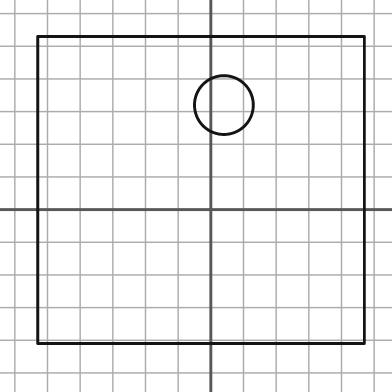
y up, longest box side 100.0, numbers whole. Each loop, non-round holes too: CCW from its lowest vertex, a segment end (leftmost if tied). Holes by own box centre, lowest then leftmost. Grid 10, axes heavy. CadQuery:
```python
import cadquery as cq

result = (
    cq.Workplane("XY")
    .moveTo(-53.0, -41.0)
    .lineTo(47.0, -41.0)
    .lineTo(47.0, 53.0)
    .lineTo(-53.0, 53.0)
    .close()
    .moveTo(4.0, 32.0)
    .circle(9.0)
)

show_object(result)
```